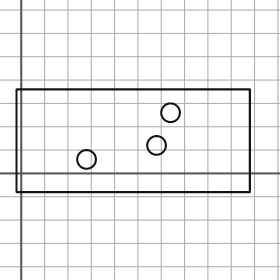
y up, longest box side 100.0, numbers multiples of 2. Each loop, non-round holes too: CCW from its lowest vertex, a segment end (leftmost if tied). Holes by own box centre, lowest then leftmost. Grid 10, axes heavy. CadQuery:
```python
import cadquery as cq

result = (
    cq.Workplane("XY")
    .moveTo(-2.0, -8.0)
    .lineTo(98.0, -8.0)
    .lineTo(98.0, 36.0)
    .lineTo(-2.0, 36.0)
    .close()
    .moveTo(28.0, 6.0)
    .circle(4.0)
    .moveTo(58.0, 12.0)
    .circle(4.0)
    .moveTo(64.0, 26.0)
    .circle(4.0)
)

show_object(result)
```